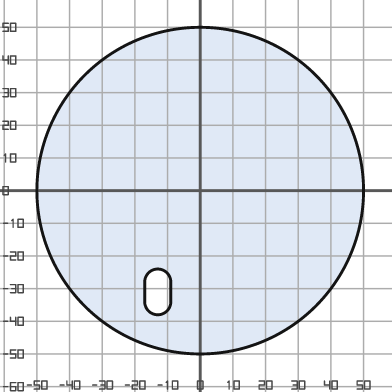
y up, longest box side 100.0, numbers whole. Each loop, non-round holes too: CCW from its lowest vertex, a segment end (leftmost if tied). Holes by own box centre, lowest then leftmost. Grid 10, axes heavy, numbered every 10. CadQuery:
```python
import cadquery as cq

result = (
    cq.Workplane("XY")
    .moveTo(0.0, 0.0)
    .circle(50.0)
    .moveTo(-17.0, -34.0)
    .threePointArc((-13.0, -38.0), (-9.0, -34.0))
    .lineTo(-9.0, -28.0)
    .threePointArc((-13.0, -24.0), (-17.0, -28.0))
    .close()
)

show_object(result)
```